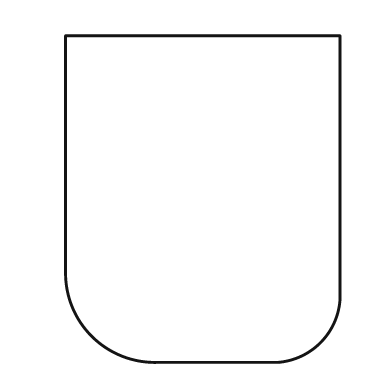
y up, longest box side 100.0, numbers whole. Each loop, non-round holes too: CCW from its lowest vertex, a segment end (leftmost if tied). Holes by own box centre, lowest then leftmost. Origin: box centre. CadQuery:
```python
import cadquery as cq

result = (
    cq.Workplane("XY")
    .moveTo(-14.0, -50.0)
    .lineTo(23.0, -50.0)
    .threePointArc((36.0, -44.0), (42.0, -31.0))
    .lineTo(42.0, 50.0)
    .lineTo(-42.0, 50.0)
    .lineTo(-42.0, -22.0)
    .threePointArc((-34.0, -42.0), (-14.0, -50.0))
    .close()
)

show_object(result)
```